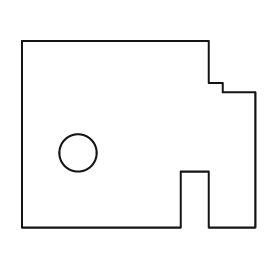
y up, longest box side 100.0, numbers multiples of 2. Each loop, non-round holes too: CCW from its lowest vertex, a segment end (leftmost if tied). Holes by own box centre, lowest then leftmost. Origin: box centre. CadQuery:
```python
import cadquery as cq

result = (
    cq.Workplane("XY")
    .moveTo(-50.0, -40.0)
    .lineTo(18.0, -40.0)
    .lineTo(18.0, -16.0)
    .lineTo(30.0, -16.0)
    .lineTo(30.0, -40.0)
    .lineTo(50.0, -40.0)
    .lineTo(50.0, 18.0)
    .lineTo(36.0, 18.0)
    .lineTo(36.0, 22.0)
    .lineTo(30.0, 22.0)
    .lineTo(30.0, 40.0)
    .lineTo(-50.0, 40.0)
    .close()
    .moveTo(-26.0, -8.0)
    .circle(8.0)
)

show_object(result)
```